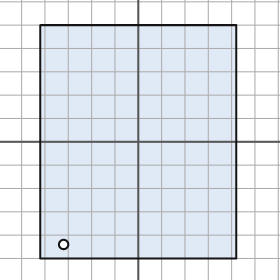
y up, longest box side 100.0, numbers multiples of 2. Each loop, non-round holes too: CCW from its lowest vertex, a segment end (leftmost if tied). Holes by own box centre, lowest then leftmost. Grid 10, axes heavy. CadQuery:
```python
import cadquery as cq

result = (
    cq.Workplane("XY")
    .moveTo(-42.0, -50.0)
    .lineTo(42.0, -50.0)
    .lineTo(42.0, 50.0)
    .lineTo(-42.0, 50.0)
    .close()
    .moveTo(-32.0, -44.0)
    .circle(2.0)
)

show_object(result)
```